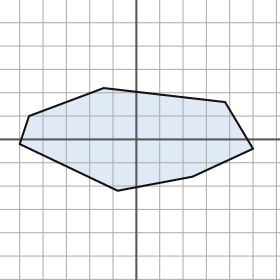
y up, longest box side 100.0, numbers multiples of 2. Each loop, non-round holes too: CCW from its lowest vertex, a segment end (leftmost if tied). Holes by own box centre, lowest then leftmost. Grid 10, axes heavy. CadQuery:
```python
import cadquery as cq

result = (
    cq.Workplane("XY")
    .moveTo(-8.0, -22.0)
    .lineTo(24.0, -16.0)
    .lineTo(50.0, -4.0)
    .lineTo(38.0, 16.0)
    .lineTo(-14.0, 22.0)
    .lineTo(-46.0, 10.0)
    .lineTo(-50.0, -2.0)
    .close()
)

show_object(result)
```